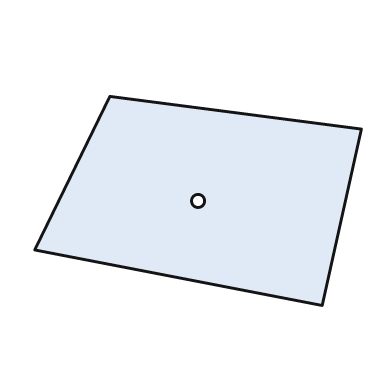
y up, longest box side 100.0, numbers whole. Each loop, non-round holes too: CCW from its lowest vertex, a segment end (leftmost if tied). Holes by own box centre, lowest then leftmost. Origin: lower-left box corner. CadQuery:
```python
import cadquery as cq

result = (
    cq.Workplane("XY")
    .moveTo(88.0, 0.0)
    .lineTo(100.0, 54.0)
    .lineTo(23.0, 64.0)
    .lineTo(0.0, 17.0)
    .close()
    .moveTo(50.0, 32.0)
    .circle(2.0)
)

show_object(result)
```